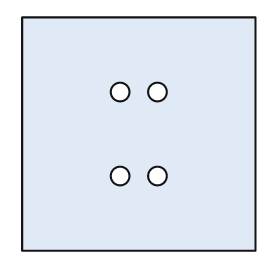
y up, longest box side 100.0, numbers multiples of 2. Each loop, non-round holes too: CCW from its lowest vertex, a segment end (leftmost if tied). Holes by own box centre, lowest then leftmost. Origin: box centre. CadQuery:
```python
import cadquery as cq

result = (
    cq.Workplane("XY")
    .moveTo(-50.0, -50.0)
    .lineTo(50.0, -50.0)
    .lineTo(50.0, 50.0)
    .lineTo(-50.0, 50.0)
    .close()
    .moveTo(-8.0, -18.0)
    .circle(4.0)
    .moveTo(8.0, -18.0)
    .circle(4.0)
    .moveTo(-8.0, 18.0)
    .circle(4.0)
    .moveTo(8.0, 18.0)
    .circle(4.0)
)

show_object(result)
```